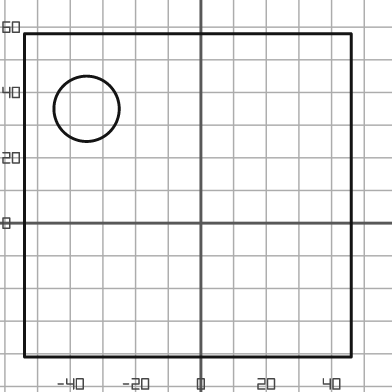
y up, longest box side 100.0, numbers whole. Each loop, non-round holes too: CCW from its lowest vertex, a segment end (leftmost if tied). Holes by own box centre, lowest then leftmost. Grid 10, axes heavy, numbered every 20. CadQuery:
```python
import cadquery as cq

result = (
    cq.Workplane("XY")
    .moveTo(-54.0, -41.0)
    .lineTo(46.0, -41.0)
    .lineTo(46.0, 58.0)
    .lineTo(-54.0, 58.0)
    .close()
    .moveTo(-35.0, 35.0)
    .circle(10.0)
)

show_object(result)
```